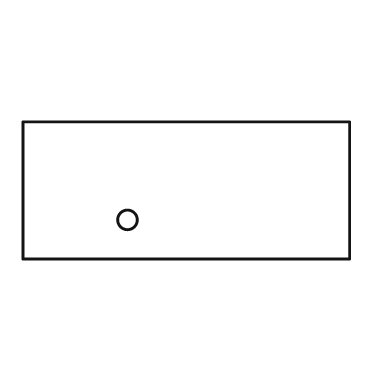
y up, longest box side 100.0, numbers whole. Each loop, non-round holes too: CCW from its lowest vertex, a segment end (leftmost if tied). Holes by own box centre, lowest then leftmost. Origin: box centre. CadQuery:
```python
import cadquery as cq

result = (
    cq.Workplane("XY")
    .moveTo(-50.0, -21.0)
    .lineTo(50.0, -21.0)
    .lineTo(50.0, 21.0)
    .lineTo(-50.0, 21.0)
    .close()
    .moveTo(-18.0, -9.0)
    .circle(3.0)
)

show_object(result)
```